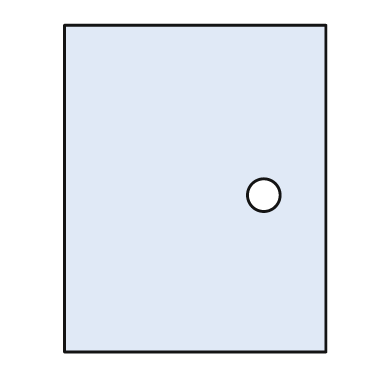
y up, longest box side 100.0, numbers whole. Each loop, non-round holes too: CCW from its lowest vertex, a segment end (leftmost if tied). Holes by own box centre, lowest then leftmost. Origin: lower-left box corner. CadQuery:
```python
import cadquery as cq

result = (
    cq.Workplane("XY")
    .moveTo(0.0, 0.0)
    .lineTo(80.0, 0.0)
    .lineTo(80.0, 100.0)
    .lineTo(0.0, 100.0)
    .close()
    .moveTo(61.0, 48.0)
    .circle(5.0)
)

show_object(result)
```